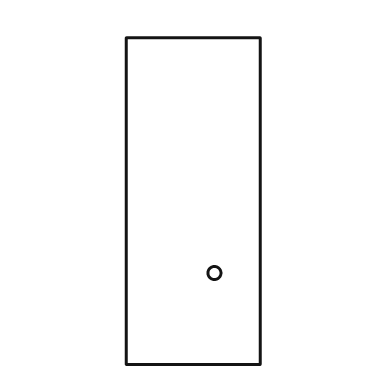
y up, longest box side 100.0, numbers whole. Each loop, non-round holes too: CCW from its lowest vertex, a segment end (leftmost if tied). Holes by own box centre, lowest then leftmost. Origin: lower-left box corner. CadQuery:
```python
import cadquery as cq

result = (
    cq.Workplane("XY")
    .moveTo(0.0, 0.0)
    .lineTo(41.0, 0.0)
    .lineTo(41.0, 100.0)
    .lineTo(0.0, 100.0)
    .close()
    .moveTo(27.0, 28.0)
    .circle(2.0)
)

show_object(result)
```